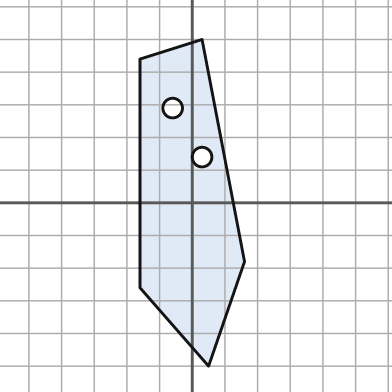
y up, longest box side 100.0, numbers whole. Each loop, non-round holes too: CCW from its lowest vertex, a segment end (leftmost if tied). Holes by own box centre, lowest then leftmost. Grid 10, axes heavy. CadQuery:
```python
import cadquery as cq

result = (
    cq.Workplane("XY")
    .moveTo(5.0, -50.0)
    .lineTo(16.0, -18.0)
    .lineTo(3.0, 50.0)
    .lineTo(-16.0, 44.0)
    .lineTo(-16.0, -26.0)
    .close()
    .moveTo(3.0, 14.0)
    .circle(3.0)
    .moveTo(-6.0, 29.0)
    .circle(3.0)
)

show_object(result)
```